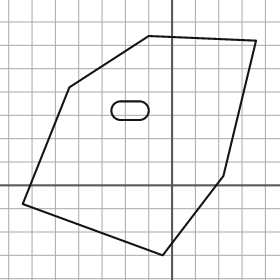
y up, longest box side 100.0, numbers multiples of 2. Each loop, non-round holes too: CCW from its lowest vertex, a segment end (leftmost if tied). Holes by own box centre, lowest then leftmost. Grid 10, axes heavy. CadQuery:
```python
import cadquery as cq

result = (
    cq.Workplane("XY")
    .moveTo(-4.0, -30.0)
    .lineTo(22.0, 4.0)
    .lineTo(36.0, 62.0)
    .lineTo(-10.0, 64.0)
    .lineTo(-44.0, 42.0)
    .lineTo(-64.0, -8.0)
    .close()
    .moveTo(-22.0, 28.0)
    .lineTo(-14.0, 28.0)
    .threePointArc((-10.0, 32.0), (-14.0, 36.0))
    .lineTo(-22.0, 36.0)
    .threePointArc((-26.0, 32.0), (-22.0, 28.0))
    .close()
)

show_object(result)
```